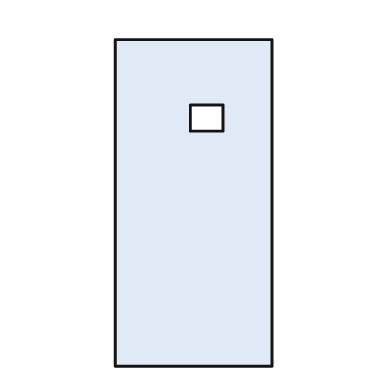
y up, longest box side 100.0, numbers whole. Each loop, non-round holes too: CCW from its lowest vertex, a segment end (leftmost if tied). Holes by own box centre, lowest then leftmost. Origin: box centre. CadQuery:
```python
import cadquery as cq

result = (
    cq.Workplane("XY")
    .moveTo(-24.0, -50.0)
    .lineTo(24.0, -50.0)
    .lineTo(24.0, 50.0)
    .lineTo(-24.0, 50.0)
    .close()
    .moveTo(-1.0, 22.0)
    .lineTo(9.0, 22.0)
    .lineTo(9.0, 30.0)
    .lineTo(-1.0, 30.0)
    .close()
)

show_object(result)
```